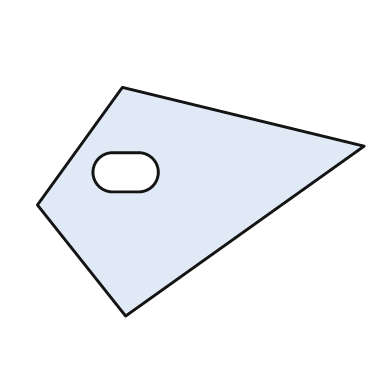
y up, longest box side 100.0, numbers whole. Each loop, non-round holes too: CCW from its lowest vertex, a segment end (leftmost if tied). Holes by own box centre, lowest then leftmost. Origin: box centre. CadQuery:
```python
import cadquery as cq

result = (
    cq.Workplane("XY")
    .moveTo(-23.0, -35.0)
    .lineTo(50.0, 17.0)
    .lineTo(-24.0, 35.0)
    .lineTo(-50.0, -1.0)
    .close()
    .moveTo(-27.0, 3.0)
    .lineTo(-19.0, 3.0)
    .threePointArc((-13.0, 9.0), (-19.0, 15.0))
    .lineTo(-27.0, 15.0)
    .threePointArc((-33.0, 9.0), (-27.0, 3.0))
    .close()
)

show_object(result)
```